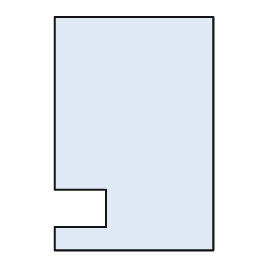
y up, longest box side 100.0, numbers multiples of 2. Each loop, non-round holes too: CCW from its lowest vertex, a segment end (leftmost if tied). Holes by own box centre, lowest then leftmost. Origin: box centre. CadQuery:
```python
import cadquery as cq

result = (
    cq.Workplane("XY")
    .moveTo(-34.0, -50.0)
    .lineTo(34.0, -50.0)
    .lineTo(34.0, 50.0)
    .lineTo(-34.0, 50.0)
    .lineTo(-34.0, -24.0)
    .lineTo(-12.0, -24.0)
    .lineTo(-12.0, -40.0)
    .lineTo(-34.0, -40.0)
    .close()
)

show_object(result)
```